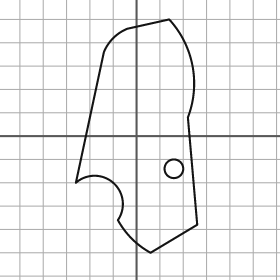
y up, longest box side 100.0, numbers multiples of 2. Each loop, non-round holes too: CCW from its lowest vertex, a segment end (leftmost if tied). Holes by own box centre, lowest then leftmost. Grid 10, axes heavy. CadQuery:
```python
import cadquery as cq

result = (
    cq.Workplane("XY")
    .moveTo(6.0, -50.0)
    .lineTo(26.0, -38.0)
    .lineTo(22.0, 8.0)
    .threePointArc((24.0, 30.0), (14.0, 50.0))
    .lineTo(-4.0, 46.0)
    .threePointArc((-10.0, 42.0), (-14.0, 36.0))
    .lineTo(-26.0, -20.0)
    .threePointArc((-10.0, -20.0), (-8.0, -36.0))
    .threePointArc((-2.0, -44.0), (6.0, -50.0))
    .close()
    .moveTo(16.0, -14.0)
    .circle(4.0)
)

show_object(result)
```